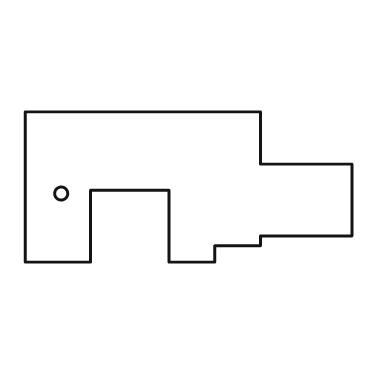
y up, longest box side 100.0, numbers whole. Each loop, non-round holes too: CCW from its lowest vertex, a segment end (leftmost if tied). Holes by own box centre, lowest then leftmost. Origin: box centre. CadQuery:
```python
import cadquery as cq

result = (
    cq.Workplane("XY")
    .moveTo(-50.0, -23.0)
    .lineTo(-30.0, -23.0)
    .lineTo(-30.0, -1.0)
    .lineTo(-6.0, -1.0)
    .lineTo(-6.0, -23.0)
    .lineTo(8.0, -23.0)
    .lineTo(8.0, -18.0)
    .lineTo(22.0, -18.0)
    .lineTo(22.0, -15.0)
    .lineTo(50.0, -15.0)
    .lineTo(50.0, 7.0)
    .lineTo(22.0, 7.0)
    .lineTo(22.0, 23.0)
    .lineTo(-50.0, 23.0)
    .close()
    .moveTo(-39.0, -2.0)
    .circle(2.0)
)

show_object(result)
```